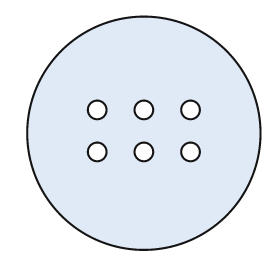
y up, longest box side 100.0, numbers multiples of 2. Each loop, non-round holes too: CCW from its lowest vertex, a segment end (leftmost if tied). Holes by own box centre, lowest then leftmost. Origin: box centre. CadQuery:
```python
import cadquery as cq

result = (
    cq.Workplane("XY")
    .moveTo(0.0, 0.0)
    .circle(50.0)
    .moveTo(-20.0, -8.0)
    .circle(4.0)
    .moveTo(0.0, -8.0)
    .circle(4.0)
    .moveTo(20.0, -8.0)
    .circle(4.0)
    .moveTo(-20.0, 10.0)
    .circle(4.0)
    .moveTo(0.0, 10.0)
    .circle(4.0)
    .moveTo(20.0, 10.0)
    .circle(4.0)
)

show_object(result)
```